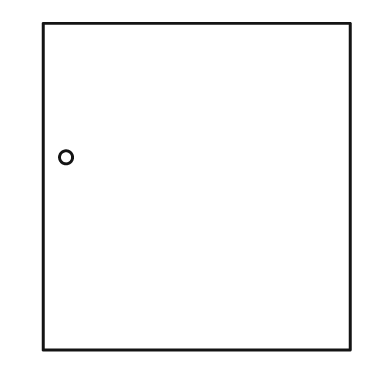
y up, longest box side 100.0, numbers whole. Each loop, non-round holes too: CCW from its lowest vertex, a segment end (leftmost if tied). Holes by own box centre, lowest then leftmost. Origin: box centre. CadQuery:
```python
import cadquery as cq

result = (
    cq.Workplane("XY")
    .moveTo(-47.0, -50.0)
    .lineTo(47.0, -50.0)
    .lineTo(47.0, 50.0)
    .lineTo(-47.0, 50.0)
    .close()
    .moveTo(-40.0, 9.0)
    .circle(2.0)
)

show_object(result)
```